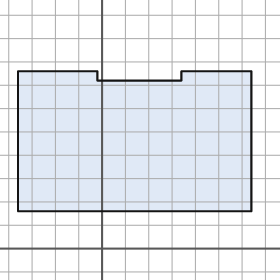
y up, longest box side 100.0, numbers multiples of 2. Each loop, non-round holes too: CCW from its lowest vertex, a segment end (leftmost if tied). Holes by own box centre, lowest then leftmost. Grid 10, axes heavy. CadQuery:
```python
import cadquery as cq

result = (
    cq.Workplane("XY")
    .moveTo(-36.0, 16.0)
    .lineTo(64.0, 16.0)
    .lineTo(64.0, 76.0)
    .lineTo(34.0, 76.0)
    .lineTo(34.0, 72.0)
    .lineTo(-2.0, 72.0)
    .lineTo(-2.0, 76.0)
    .lineTo(-36.0, 76.0)
    .close()
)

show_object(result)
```